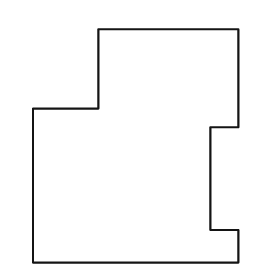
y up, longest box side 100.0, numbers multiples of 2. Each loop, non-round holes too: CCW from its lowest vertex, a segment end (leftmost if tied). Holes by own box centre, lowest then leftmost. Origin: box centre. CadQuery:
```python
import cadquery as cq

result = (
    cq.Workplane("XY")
    .moveTo(-44.0, -50.0)
    .lineTo(44.0, -50.0)
    .lineTo(44.0, -36.0)
    .lineTo(32.0, -36.0)
    .lineTo(32.0, 8.0)
    .lineTo(44.0, 8.0)
    .lineTo(44.0, 50.0)
    .lineTo(-16.0, 50.0)
    .lineTo(-16.0, 16.0)
    .lineTo(-44.0, 16.0)
    .close()
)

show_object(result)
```